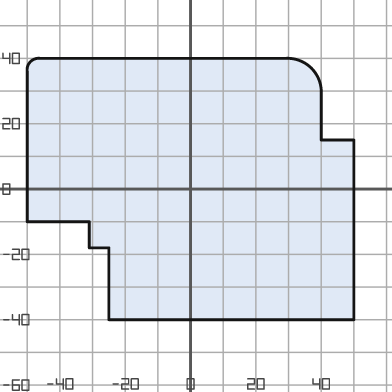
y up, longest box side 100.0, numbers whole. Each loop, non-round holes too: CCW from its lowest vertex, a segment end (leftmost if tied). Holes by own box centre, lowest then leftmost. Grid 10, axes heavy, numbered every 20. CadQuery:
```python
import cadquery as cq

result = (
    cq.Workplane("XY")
    .moveTo(-25.0, -40.0)
    .lineTo(50.0, -40.0)
    .lineTo(50.0, 15.0)
    .lineTo(40.0, 15.0)
    .lineTo(40.0, 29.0)
    .threePointArc((37.0, 37.0), (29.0, 40.0))
    .lineTo(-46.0, 40.0)
    .threePointArc((-49.0, 39.0), (-50.0, 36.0))
    .lineTo(-50.0, -10.0)
    .lineTo(-31.0, -10.0)
    .lineTo(-31.0, -18.0)
    .lineTo(-25.0, -18.0)
    .close()
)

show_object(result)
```